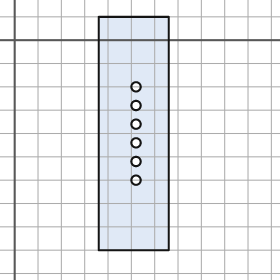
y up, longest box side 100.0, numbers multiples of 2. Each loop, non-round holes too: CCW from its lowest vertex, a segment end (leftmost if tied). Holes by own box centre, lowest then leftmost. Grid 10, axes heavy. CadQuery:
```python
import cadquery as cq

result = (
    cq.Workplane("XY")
    .moveTo(36.0, -90.0)
    .lineTo(66.0, -90.0)
    .lineTo(66.0, 10.0)
    .lineTo(36.0, 10.0)
    .close()
    .moveTo(52.0, -60.0)
    .circle(2.0)
    .moveTo(52.0, -52.0)
    .circle(2.0)
    .moveTo(52.0, -44.0)
    .circle(2.0)
    .moveTo(52.0, -36.0)
    .circle(2.0)
    .moveTo(52.0, -28.0)
    .circle(2.0)
    .moveTo(52.0, -20.0)
    .circle(2.0)
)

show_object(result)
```